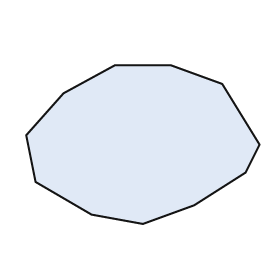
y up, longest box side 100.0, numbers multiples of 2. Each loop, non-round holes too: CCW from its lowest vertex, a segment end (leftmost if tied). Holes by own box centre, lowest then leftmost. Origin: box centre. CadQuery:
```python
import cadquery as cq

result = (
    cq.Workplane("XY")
    .moveTo(0.0, -34.0)
    .lineTo(22.0, -26.0)
    .lineTo(44.0, -12.0)
    .lineTo(50.0, 0.0)
    .lineTo(34.0, 26.0)
    .lineTo(12.0, 34.0)
    .lineTo(-12.0, 34.0)
    .lineTo(-34.0, 22.0)
    .lineTo(-50.0, 4.0)
    .lineTo(-46.0, -16.0)
    .lineTo(-22.0, -30.0)
    .close()
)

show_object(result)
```